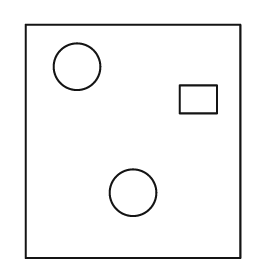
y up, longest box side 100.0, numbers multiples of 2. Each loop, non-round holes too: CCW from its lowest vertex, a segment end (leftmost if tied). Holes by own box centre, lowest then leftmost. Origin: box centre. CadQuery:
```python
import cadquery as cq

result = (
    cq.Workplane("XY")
    .moveTo(-46.0, -50.0)
    .lineTo(46.0, -50.0)
    .lineTo(46.0, 50.0)
    .lineTo(-46.0, 50.0)
    .close()
    .moveTo(0.0, -22.0)
    .circle(10.0)
    .moveTo(20.0, 12.0)
    .lineTo(36.0, 12.0)
    .lineTo(36.0, 24.0)
    .lineTo(20.0, 24.0)
    .close()
    .moveTo(-24.0, 32.0)
    .circle(10.0)
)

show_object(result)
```